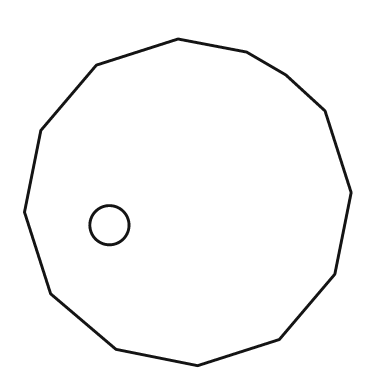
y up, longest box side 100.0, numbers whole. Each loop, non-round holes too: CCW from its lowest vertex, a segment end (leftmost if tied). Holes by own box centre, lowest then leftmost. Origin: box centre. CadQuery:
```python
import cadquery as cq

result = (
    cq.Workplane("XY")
    .moveTo(3.0, -50.0)
    .lineTo(28.0, -42.0)
    .lineTo(45.0, -22.0)
    .lineTo(50.0, 3.0)
    .lineTo(42.0, 28.0)
    .lineTo(30.0, 39.0)
    .lineTo(18.0, 46.0)
    .lineTo(-3.0, 50.0)
    .lineTo(-28.0, 42.0)
    .lineTo(-45.0, 22.0)
    .lineTo(-50.0, -3.0)
    .lineTo(-42.0, -28.0)
    .lineTo(-22.0, -45.0)
    .close()
    .moveTo(-24.0, -7.0)
    .circle(6.0)
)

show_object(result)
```